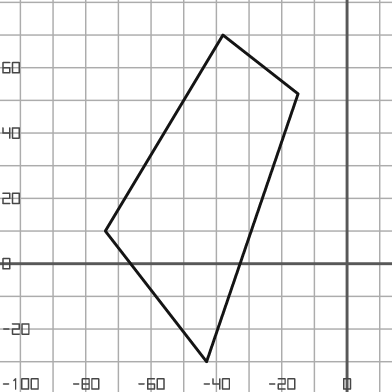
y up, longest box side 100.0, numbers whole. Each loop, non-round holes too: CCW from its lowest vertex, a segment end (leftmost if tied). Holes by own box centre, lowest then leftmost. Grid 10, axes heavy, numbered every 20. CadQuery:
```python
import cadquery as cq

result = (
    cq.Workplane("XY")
    .moveTo(-43.0, -30.0)
    .lineTo(-15.0, 52.0)
    .lineTo(-38.0, 70.0)
    .lineTo(-74.0, 10.0)
    .close()
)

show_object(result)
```